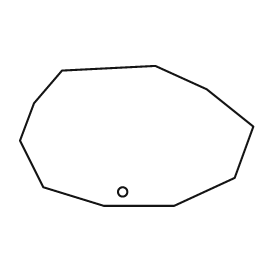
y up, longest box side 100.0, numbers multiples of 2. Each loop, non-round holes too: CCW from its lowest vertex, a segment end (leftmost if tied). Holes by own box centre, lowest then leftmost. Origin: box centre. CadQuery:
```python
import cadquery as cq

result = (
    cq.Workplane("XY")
    .moveTo(-14.0, -30.0)
    .lineTo(16.0, -30.0)
    .lineTo(42.0, -18.0)
    .lineTo(50.0, 4.0)
    .lineTo(30.0, 20.0)
    .lineTo(8.0, 30.0)
    .lineTo(-32.0, 28.0)
    .lineTo(-44.0, 14.0)
    .lineTo(-50.0, -2.0)
    .lineTo(-40.0, -22.0)
    .close()
    .moveTo(-6.0, -24.0)
    .circle(2.0)
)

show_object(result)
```